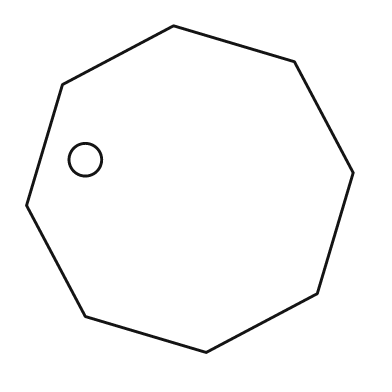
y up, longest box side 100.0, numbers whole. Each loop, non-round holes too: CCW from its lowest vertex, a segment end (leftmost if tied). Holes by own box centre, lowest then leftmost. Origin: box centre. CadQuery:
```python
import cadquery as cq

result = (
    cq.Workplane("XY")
    .moveTo(5.0, -50.0)
    .lineTo(39.0, -32.0)
    .lineTo(50.0, 5.0)
    .lineTo(32.0, 39.0)
    .lineTo(-5.0, 50.0)
    .lineTo(-39.0, 32.0)
    .lineTo(-50.0, -5.0)
    .lineTo(-32.0, -39.0)
    .close()
    .moveTo(-32.0, 9.0)
    .circle(5.0)
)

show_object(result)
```